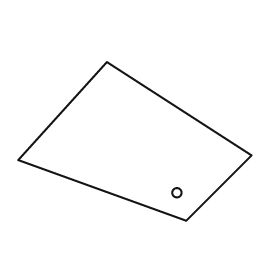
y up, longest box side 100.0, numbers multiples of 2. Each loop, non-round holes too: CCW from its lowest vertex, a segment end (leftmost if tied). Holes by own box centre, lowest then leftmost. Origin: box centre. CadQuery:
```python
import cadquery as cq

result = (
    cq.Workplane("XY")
    .moveTo(22.0, -34.0)
    .lineTo(50.0, -6.0)
    .lineTo(-12.0, 34.0)
    .lineTo(-50.0, -8.0)
    .close()
    .moveTo(18.0, -22.0)
    .circle(2.0)
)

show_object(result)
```